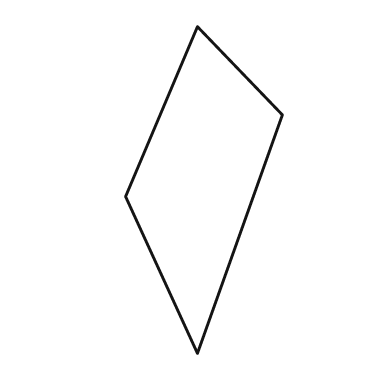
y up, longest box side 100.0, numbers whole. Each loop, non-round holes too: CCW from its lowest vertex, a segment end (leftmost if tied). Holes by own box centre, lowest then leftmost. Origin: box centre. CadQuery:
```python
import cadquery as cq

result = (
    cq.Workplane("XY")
    .moveTo(-2.0, -50.0)
    .lineTo(24.0, 23.0)
    .lineTo(-2.0, 50.0)
    .lineTo(-24.0, -2.0)
    .close()
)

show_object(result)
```